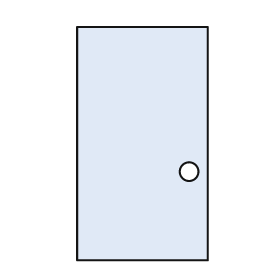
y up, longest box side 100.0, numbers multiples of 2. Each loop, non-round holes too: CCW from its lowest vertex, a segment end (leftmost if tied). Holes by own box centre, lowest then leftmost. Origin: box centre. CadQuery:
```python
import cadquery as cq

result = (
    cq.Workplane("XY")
    .moveTo(-28.0, -50.0)
    .lineTo(28.0, -50.0)
    .lineTo(28.0, 50.0)
    .lineTo(-28.0, 50.0)
    .close()
    .moveTo(20.0, -12.0)
    .circle(4.0)
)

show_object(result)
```